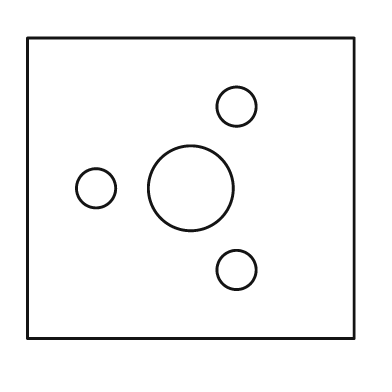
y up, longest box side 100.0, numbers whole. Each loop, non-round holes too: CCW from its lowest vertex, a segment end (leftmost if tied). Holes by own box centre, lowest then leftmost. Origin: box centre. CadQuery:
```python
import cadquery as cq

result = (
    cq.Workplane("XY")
    .moveTo(-50.0, -46.0)
    .lineTo(50.0, -46.0)
    .lineTo(50.0, 46.0)
    .lineTo(-50.0, 46.0)
    .close()
    .moveTo(14.0, -25.0)
    .circle(6.0)
    .moveTo(-29.0, 0.0)
    .circle(6.0)
    .moveTo(0.0, 0.0)
    .circle(13.0)
    .moveTo(14.0, 25.0)
    .circle(6.0)
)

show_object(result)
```